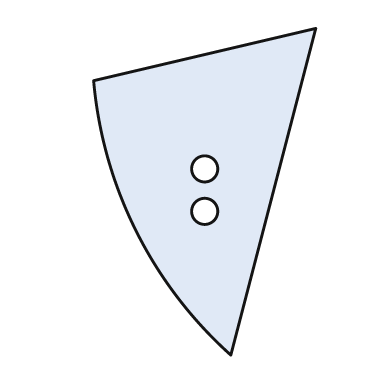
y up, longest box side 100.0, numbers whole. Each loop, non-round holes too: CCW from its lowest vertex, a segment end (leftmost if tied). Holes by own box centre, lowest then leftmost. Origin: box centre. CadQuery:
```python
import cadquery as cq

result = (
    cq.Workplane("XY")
    .moveTo(8.0, -50.0)
    .lineTo(34.0, 50.0)
    .lineTo(-34.0, 34.0)
    .threePointArc((-21.0, -12.0), (8.0, -50.0))
    .close()
    .moveTo(0.0, -6.0)
    .circle(4.0)
    .moveTo(0.0, 7.0)
    .circle(4.0)
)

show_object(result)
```